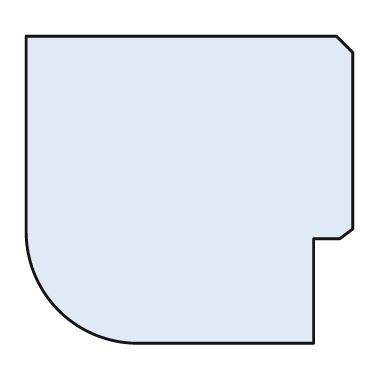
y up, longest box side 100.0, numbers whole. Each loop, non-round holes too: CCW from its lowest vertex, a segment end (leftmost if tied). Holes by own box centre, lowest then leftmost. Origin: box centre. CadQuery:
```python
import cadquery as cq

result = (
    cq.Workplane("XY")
    .moveTo(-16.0, -47.0)
    .lineTo(38.0, -47.0)
    .lineTo(38.0, -15.0)
    .lineTo(46.0, -15.0)
    .lineTo(50.0, -12.0)
    .lineTo(50.0, 42.0)
    .lineTo(45.0, 47.0)
    .lineTo(-50.0, 47.0)
    .lineTo(-50.0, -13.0)
    .threePointArc((-40.0, -37.0), (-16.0, -47.0))
    .close()
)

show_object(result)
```